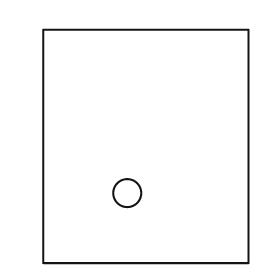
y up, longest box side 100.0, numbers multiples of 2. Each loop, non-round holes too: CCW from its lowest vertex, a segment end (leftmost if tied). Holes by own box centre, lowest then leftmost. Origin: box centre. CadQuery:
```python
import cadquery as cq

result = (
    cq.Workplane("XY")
    .moveTo(-44.0, -50.0)
    .lineTo(44.0, -50.0)
    .lineTo(44.0, 50.0)
    .lineTo(-44.0, 50.0)
    .close()
    .moveTo(-8.0, -20.0)
    .circle(6.0)
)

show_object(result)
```